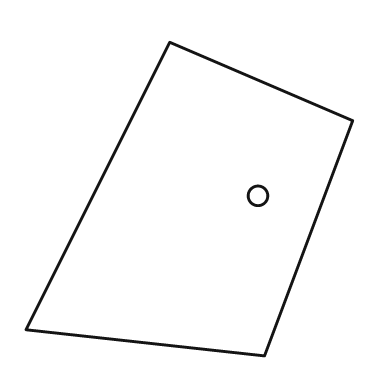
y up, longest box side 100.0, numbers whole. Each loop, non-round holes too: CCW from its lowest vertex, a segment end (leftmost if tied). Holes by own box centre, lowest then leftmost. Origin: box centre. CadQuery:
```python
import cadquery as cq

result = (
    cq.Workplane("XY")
    .moveTo(23.0, -48.0)
    .lineTo(50.0, 24.0)
    .lineTo(-6.0, 48.0)
    .lineTo(-50.0, -40.0)
    .close()
    .moveTo(21.0, 1.0)
    .circle(3.0)
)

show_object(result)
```